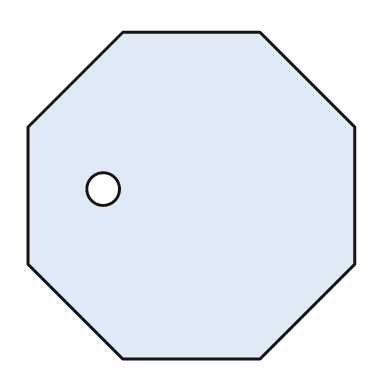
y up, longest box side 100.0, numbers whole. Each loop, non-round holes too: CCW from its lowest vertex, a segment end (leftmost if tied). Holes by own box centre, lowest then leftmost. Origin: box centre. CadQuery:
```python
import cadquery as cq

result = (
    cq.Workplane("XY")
    .moveTo(-21.0, -50.0)
    .lineTo(21.0, -50.0)
    .lineTo(50.0, -21.0)
    .lineTo(50.0, 21.0)
    .lineTo(21.0, 50.0)
    .lineTo(-21.0, 50.0)
    .lineTo(-50.0, 21.0)
    .lineTo(-50.0, -21.0)
    .close()
    .moveTo(-27.0, 2.0)
    .circle(5.0)
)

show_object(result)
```